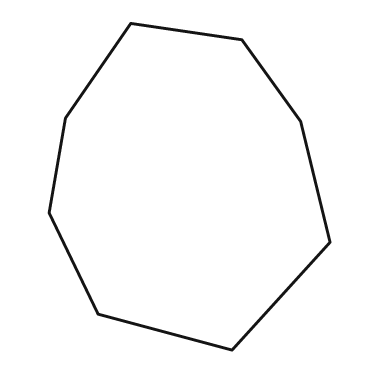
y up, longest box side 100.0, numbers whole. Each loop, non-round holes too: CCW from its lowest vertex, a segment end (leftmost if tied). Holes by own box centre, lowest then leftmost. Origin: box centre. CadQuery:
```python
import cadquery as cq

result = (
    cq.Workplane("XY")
    .moveTo(13.0, -50.0)
    .lineTo(43.0, -17.0)
    .lineTo(34.0, 20.0)
    .lineTo(16.0, 45.0)
    .lineTo(-18.0, 50.0)
    .lineTo(-38.0, 21.0)
    .lineTo(-43.0, -8.0)
    .lineTo(-28.0, -39.0)
    .close()
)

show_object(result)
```